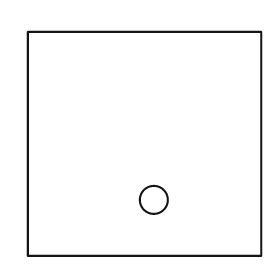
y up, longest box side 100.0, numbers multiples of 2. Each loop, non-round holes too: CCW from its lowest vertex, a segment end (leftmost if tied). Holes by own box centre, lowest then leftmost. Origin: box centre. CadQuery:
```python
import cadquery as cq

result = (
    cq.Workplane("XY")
    .moveTo(-50.0, -48.0)
    .lineTo(50.0, -48.0)
    .lineTo(50.0, 48.0)
    .lineTo(-50.0, 48.0)
    .close()
    .moveTo(4.0, -24.0)
    .circle(6.0)
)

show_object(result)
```